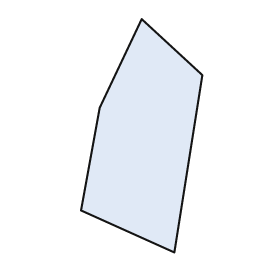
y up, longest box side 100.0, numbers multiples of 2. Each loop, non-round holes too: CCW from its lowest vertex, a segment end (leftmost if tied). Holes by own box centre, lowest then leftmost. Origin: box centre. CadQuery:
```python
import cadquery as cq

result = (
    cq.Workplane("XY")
    .moveTo(14.0, -50.0)
    .lineTo(26.0, 26.0)
    .lineTo(0.0, 50.0)
    .lineTo(-18.0, 12.0)
    .lineTo(-26.0, -32.0)
    .close()
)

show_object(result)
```